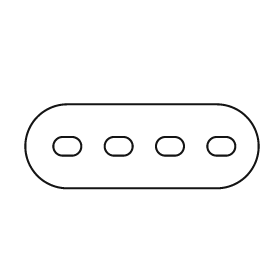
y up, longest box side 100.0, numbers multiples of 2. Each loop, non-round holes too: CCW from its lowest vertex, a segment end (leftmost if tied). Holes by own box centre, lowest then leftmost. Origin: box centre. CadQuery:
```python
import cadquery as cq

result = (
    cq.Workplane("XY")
    .moveTo(-32.0, -18.0)
    .lineTo(32.0, -18.0)
    .threePointArc((50.0, 0.0), (32.0, 18.0))
    .lineTo(-32.0, 18.0)
    .threePointArc((-50.0, 0.0), (-32.0, -18.0))
    .close()
    .moveTo(-34.0, -4.0)
    .lineTo(-30.0, -4.0)
    .threePointArc((-26.0, 0.0), (-30.0, 4.0))
    .lineTo(-34.0, 4.0)
    .threePointArc((-38.0, 0.0), (-34.0, -4.0))
    .close()
    .moveTo(-12.0, -4.0)
    .lineTo(-8.0, -4.0)
    .threePointArc((-4.0, 0.0), (-8.0, 4.0))
    .lineTo(-12.0, 4.0)
    .threePointArc((-16.0, 0.0), (-12.0, -4.0))
    .close()
    .moveTo(10.0, -4.0)
    .lineTo(14.0, -4.0)
    .threePointArc((18.0, 0.0), (14.0, 4.0))
    .lineTo(10.0, 4.0)
    .threePointArc((6.0, 0.0), (10.0, -4.0))
    .close()
    .moveTo(32.0, -4.0)
    .lineTo(36.0, -4.0)
    .threePointArc((40.0, 0.0), (36.0, 4.0))
    .lineTo(32.0, 4.0)
    .threePointArc((28.0, 0.0), (32.0, -4.0))
    .close()
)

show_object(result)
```